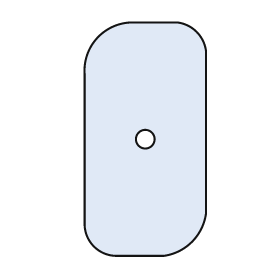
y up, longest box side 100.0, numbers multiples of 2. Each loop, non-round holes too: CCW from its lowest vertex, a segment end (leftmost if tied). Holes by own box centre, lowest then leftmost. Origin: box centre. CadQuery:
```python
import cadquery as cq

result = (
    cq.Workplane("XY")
    .moveTo(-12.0, -50.0)
    .lineTo(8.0, -50.0)
    .threePointArc((20.0, -44.0), (26.0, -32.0))
    .lineTo(26.0, 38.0)
    .threePointArc((22.0, 46.0), (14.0, 50.0))
    .lineTo(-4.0, 50.0)
    .threePointArc((-20.0, 44.0), (-26.0, 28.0))
    .lineTo(-26.0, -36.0)
    .threePointArc((-22.0, -46.0), (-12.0, -50.0))
    .close()
    .moveTo(0.0, 0.0)
    .circle(4.0)
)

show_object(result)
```